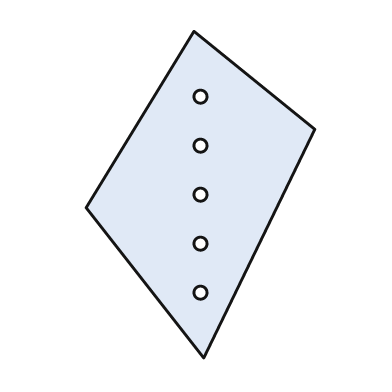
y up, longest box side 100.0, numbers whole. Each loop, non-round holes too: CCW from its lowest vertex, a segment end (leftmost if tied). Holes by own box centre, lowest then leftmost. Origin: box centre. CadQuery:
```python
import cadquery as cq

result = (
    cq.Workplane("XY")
    .moveTo(1.0, -50.0)
    .lineTo(35.0, 20.0)
    .lineTo(-2.0, 50.0)
    .lineTo(-35.0, -4.0)
    .close()
    .moveTo(0.0, -30.0)
    .circle(2.0)
    .moveTo(0.0, -15.0)
    .circle(2.0)
    .moveTo(0.0, 0.0)
    .circle(2.0)
    .moveTo(0.0, 15.0)
    .circle(2.0)
    .moveTo(0.0, 30.0)
    .circle(2.0)
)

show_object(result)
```